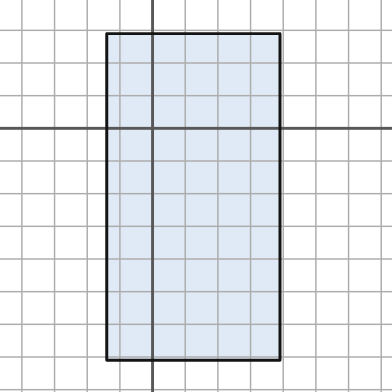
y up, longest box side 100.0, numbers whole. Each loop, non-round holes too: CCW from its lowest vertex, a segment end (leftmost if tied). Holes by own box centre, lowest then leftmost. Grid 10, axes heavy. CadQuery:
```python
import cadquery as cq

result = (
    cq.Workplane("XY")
    .moveTo(-14.0, -71.0)
    .lineTo(39.0, -71.0)
    .lineTo(39.0, 29.0)
    .lineTo(-14.0, 29.0)
    .close()
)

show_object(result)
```